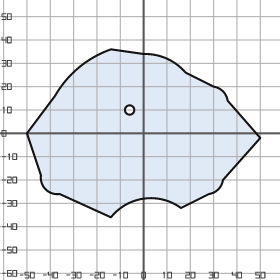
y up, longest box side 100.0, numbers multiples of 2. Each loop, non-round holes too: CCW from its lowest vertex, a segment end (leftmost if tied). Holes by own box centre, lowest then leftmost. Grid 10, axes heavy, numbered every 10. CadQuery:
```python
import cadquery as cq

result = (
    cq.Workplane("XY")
    .moveTo(-14.0, -36.0)
    .threePointArc((0.0, -28.0), (16.0, -32.0))
    .lineTo(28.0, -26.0)
    .threePointArc((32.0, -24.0), (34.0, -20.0))
    .lineTo(50.0, -2.0)
    .lineTo(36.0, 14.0)
    .threePointArc((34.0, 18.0), (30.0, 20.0))
    .lineTo(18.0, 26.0)
    .threePointArc((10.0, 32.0), (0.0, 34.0))
    .lineTo(-14.0, 36.0)
    .threePointArc((-28.0, 28.0), (-38.0, 16.0))
    .lineTo(-50.0, 0.0)
    .lineTo(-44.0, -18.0)
    .threePointArc((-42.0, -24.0), (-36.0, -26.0))
    .close()
    .moveTo(-6.0, 10.0)
    .circle(2.0)
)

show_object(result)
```